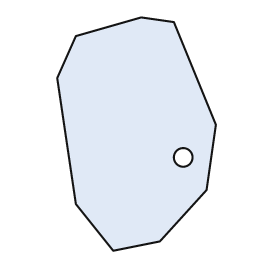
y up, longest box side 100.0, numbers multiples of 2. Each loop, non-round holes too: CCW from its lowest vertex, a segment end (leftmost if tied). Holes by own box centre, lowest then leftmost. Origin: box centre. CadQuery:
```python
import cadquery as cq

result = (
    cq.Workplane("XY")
    .moveTo(-10.0, -50.0)
    .lineTo(10.0, -46.0)
    .lineTo(30.0, -24.0)
    .lineTo(34.0, 4.0)
    .lineTo(16.0, 48.0)
    .lineTo(2.0, 50.0)
    .lineTo(-26.0, 42.0)
    .lineTo(-34.0, 24.0)
    .lineTo(-26.0, -30.0)
    .close()
    .moveTo(20.0, -10.0)
    .circle(4.0)
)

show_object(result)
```